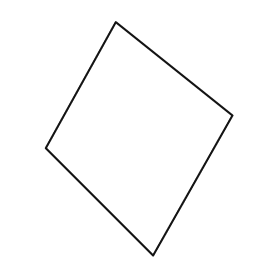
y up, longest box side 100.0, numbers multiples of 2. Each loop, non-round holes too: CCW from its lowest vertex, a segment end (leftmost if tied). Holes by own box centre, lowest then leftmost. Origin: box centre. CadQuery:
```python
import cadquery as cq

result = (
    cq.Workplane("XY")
    .moveTo(6.0, -50.0)
    .lineTo(40.0, 10.0)
    .lineTo(-10.0, 50.0)
    .lineTo(-40.0, -4.0)
    .close()
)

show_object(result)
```